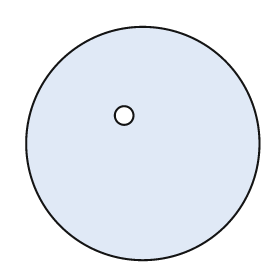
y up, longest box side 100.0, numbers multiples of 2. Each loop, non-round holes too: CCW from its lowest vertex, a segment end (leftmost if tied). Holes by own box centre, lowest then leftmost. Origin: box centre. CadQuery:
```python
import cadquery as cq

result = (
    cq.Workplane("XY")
    .moveTo(0.0, 0.0)
    .circle(50.0)
    .moveTo(-8.0, 12.0)
    .circle(4.0)
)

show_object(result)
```